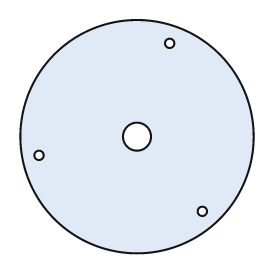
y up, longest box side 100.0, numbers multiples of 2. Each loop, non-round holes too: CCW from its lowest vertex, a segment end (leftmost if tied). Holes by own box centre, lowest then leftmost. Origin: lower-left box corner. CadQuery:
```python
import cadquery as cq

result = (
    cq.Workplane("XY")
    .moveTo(50.0, 50.0)
    .circle(50.0)
    .moveTo(78.0, 18.0)
    .circle(2.0)
    .moveTo(8.0, 42.0)
    .circle(2.0)
    .moveTo(50.0, 50.0)
    .circle(6.0)
    .moveTo(64.0, 90.0)
    .circle(2.0)
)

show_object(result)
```